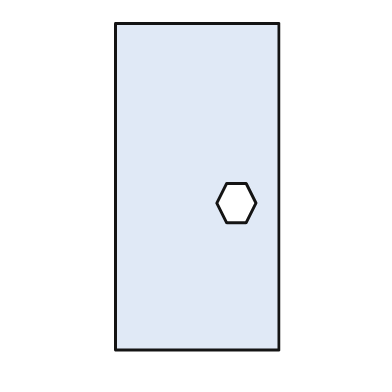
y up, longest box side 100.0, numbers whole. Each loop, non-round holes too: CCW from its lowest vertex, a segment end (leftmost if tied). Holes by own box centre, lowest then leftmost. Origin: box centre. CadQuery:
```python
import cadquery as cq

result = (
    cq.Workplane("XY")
    .moveTo(-25.0, -50.0)
    .lineTo(25.0, -50.0)
    .lineTo(25.0, 50.0)
    .lineTo(-25.0, 50.0)
    .close()
    .moveTo(9.0, -11.0)
    .lineTo(15.0, -11.0)
    .lineTo(18.0, -5.0)
    .lineTo(15.0, 1.0)
    .lineTo(9.0, 1.0)
    .lineTo(6.0, -5.0)
    .close()
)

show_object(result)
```